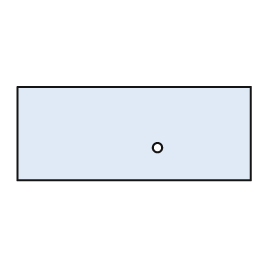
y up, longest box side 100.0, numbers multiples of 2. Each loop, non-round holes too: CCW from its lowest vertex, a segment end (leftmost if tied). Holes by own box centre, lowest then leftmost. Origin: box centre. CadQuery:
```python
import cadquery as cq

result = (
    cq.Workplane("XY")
    .moveTo(-50.0, -20.0)
    .lineTo(50.0, -20.0)
    .lineTo(50.0, 20.0)
    .lineTo(-50.0, 20.0)
    .close()
    .moveTo(10.0, -6.0)
    .circle(2.0)
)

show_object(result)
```